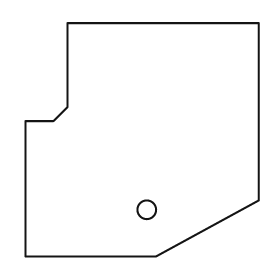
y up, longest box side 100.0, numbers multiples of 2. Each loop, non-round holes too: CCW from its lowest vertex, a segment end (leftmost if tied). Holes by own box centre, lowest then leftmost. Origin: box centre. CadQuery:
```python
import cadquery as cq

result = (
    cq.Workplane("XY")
    .moveTo(-50.0, -50.0)
    .lineTo(6.0, -50.0)
    .lineTo(50.0, -26.0)
    .lineTo(50.0, 50.0)
    .lineTo(-32.0, 50.0)
    .lineTo(-32.0, 14.0)
    .lineTo(-38.0, 8.0)
    .lineTo(-50.0, 8.0)
    .close()
    .moveTo(2.0, -30.0)
    .circle(4.0)
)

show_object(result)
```